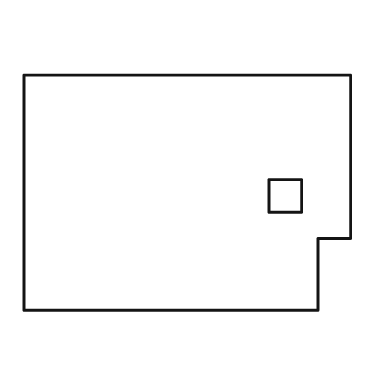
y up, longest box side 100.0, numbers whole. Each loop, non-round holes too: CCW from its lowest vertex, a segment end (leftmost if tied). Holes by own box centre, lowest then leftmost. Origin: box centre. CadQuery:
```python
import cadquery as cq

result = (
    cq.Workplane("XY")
    .moveTo(-50.0, -36.0)
    .lineTo(40.0, -36.0)
    .lineTo(40.0, -14.0)
    .lineTo(50.0, -14.0)
    .lineTo(50.0, 36.0)
    .lineTo(-50.0, 36.0)
    .close()
    .moveTo(25.0, -6.0)
    .lineTo(35.0, -6.0)
    .lineTo(35.0, 4.0)
    .lineTo(25.0, 4.0)
    .close()
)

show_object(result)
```